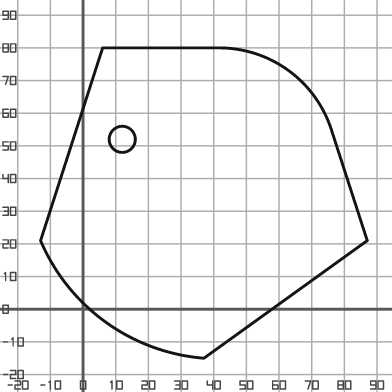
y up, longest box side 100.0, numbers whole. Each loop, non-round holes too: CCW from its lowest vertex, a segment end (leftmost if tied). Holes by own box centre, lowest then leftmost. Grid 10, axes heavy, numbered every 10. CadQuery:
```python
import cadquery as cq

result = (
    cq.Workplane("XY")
    .moveTo(37.0, -15.0)
    .lineTo(87.0, 21.0)
    .lineTo(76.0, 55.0)
    .threePointArc((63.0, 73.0), (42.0, 80.0))
    .lineTo(6.0, 80.0)
    .lineTo(-13.0, 21.0)
    .threePointArc((7.0, -4.0), (37.0, -15.0))
    .close()
    .moveTo(12.0, 52.0)
    .circle(4.0)
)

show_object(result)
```